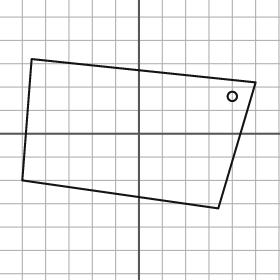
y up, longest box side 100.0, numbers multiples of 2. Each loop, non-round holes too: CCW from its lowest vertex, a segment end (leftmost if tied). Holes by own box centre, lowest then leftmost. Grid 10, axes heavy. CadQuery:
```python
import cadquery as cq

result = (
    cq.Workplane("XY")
    .moveTo(34.0, -32.0)
    .lineTo(50.0, 22.0)
    .lineTo(-46.0, 32.0)
    .lineTo(-50.0, -20.0)
    .close()
    .moveTo(40.0, 16.0)
    .circle(2.0)
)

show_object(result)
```